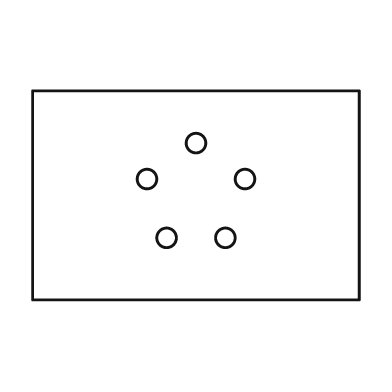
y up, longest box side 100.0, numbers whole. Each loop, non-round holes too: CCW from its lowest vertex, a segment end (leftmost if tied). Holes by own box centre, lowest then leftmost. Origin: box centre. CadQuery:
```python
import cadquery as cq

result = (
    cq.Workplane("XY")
    .moveTo(-50.0, -32.0)
    .lineTo(50.0, -32.0)
    .lineTo(50.0, 32.0)
    .lineTo(-50.0, 32.0)
    .close()
    .moveTo(-9.0, -13.0)
    .circle(3.0)
    .moveTo(9.0, -13.0)
    .circle(3.0)
    .moveTo(-15.0, 5.0)
    .circle(3.0)
    .moveTo(15.0, 5.0)
    .circle(3.0)
    .moveTo(0.0, 16.0)
    .circle(3.0)
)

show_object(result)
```